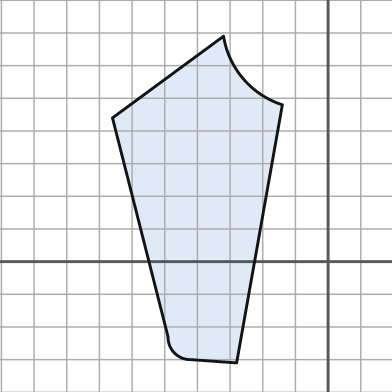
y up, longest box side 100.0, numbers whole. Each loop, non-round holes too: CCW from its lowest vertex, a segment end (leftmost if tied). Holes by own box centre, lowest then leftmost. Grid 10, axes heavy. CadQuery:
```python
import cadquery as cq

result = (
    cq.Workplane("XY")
    .moveTo(-28.0, -31.0)
    .lineTo(-14.0, 48.0)
    .threePointArc((-26.0, 56.0), (-32.0, 69.0))
    .lineTo(-66.0, 44.0)
    .lineTo(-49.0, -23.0)
    .threePointArc((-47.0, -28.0), (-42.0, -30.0))
    .close()
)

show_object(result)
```